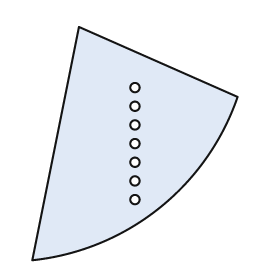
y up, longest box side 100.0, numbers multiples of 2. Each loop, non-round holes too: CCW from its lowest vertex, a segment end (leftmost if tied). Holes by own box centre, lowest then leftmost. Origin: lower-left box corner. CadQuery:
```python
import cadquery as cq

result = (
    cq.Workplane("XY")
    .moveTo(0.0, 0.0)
    .threePointArc((54.0, 22.0), (88.0, 70.0))
    .lineTo(20.0, 100.0)
    .close()
    .moveTo(44.0, 26.0)
    .circle(2.0)
    .moveTo(44.0, 34.0)
    .circle(2.0)
    .moveTo(44.0, 42.0)
    .circle(2.0)
    .moveTo(44.0, 50.0)
    .circle(2.0)
    .moveTo(44.0, 58.0)
    .circle(2.0)
    .moveTo(44.0, 66.0)
    .circle(2.0)
    .moveTo(44.0, 74.0)
    .circle(2.0)
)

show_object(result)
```